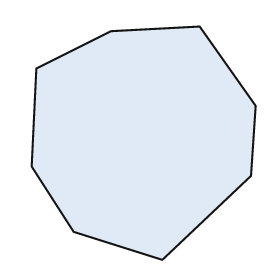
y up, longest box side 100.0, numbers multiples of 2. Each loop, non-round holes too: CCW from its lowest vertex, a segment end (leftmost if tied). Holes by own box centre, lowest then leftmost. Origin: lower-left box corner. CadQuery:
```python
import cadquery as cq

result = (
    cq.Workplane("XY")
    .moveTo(56.0, 0.0)
    .lineTo(94.0, 36.0)
    .lineTo(96.0, 66.0)
    .lineTo(72.0, 100.0)
    .lineTo(34.0, 98.0)
    .lineTo(2.0, 82.0)
    .lineTo(0.0, 40.0)
    .lineTo(18.0, 12.0)
    .close()
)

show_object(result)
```